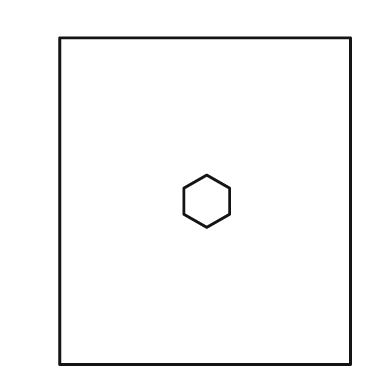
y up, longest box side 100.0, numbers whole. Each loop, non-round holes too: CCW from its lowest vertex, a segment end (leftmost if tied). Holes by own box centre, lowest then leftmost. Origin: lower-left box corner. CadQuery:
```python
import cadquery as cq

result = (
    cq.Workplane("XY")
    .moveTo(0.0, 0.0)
    .lineTo(89.0, 0.0)
    .lineTo(89.0, 100.0)
    .lineTo(0.0, 100.0)
    .close()
    .moveTo(45.0, 42.0)
    .lineTo(52.0, 46.0)
    .lineTo(52.0, 54.0)
    .lineTo(45.0, 58.0)
    .lineTo(38.0, 54.0)
    .lineTo(38.0, 46.0)
    .close()
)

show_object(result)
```